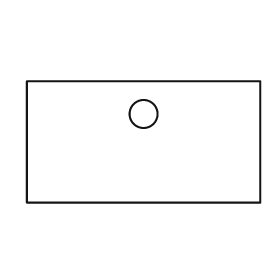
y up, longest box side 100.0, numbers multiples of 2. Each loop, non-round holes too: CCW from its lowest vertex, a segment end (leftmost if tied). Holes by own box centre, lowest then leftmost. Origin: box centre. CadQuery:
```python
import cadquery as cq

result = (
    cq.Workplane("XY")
    .moveTo(-50.0, -26.0)
    .lineTo(50.0, -26.0)
    .lineTo(50.0, 26.0)
    .lineTo(-50.0, 26.0)
    .close()
    .moveTo(0.0, 12.0)
    .circle(6.0)
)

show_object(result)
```